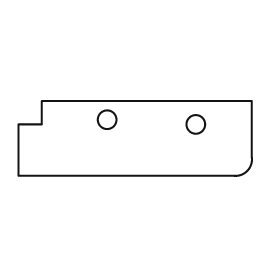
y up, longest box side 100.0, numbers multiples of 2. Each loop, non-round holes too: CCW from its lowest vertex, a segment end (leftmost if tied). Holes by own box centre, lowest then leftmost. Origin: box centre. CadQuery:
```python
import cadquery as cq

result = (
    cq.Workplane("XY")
    .moveTo(-50.0, -16.0)
    .lineTo(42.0, -16.0)
    .threePointArc((48.0, -14.0), (50.0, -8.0))
    .lineTo(50.0, 16.0)
    .lineTo(-40.0, 16.0)
    .lineTo(-40.0, 6.0)
    .lineTo(-50.0, 6.0)
    .close()
    .moveTo(26.0, 6.0)
    .circle(4.0)
    .moveTo(-12.0, 8.0)
    .circle(4.0)
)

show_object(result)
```